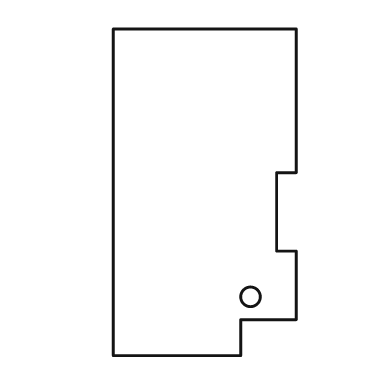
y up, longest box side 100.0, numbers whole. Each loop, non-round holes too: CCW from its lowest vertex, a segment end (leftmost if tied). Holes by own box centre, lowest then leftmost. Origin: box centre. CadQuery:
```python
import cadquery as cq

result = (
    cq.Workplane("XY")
    .moveTo(-28.0, -50.0)
    .lineTo(11.0, -50.0)
    .lineTo(11.0, -39.0)
    .lineTo(28.0, -39.0)
    .lineTo(28.0, -18.0)
    .lineTo(22.0, -18.0)
    .lineTo(22.0, 6.0)
    .lineTo(28.0, 6.0)
    .lineTo(28.0, 50.0)
    .lineTo(-28.0, 50.0)
    .close()
    .moveTo(14.0, -32.0)
    .circle(3.0)
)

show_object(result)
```